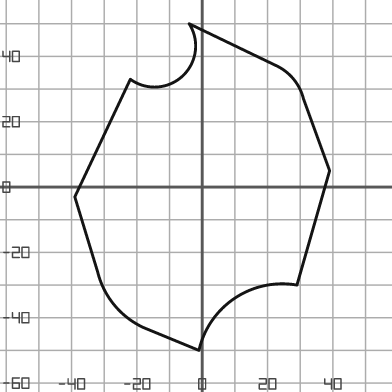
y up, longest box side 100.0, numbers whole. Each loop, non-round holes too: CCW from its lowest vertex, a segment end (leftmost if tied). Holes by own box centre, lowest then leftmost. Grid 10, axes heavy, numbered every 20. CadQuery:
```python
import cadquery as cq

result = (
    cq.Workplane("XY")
    .moveTo(-1.0, -50.0)
    .threePointArc((10.0, -34.0), (29.0, -30.0))
    .lineTo(39.0, 5.0)
    .lineTo(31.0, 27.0)
    .threePointArc((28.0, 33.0), (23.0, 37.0))
    .lineTo(-4.0, 50.0)
    .threePointArc((-6.0, 34.0), (-22.0, 33.0))
    .lineTo(-39.0, -3.0)
    .lineTo(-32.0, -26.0)
    .threePointArc((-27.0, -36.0), (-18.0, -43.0))
    .close()
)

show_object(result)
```